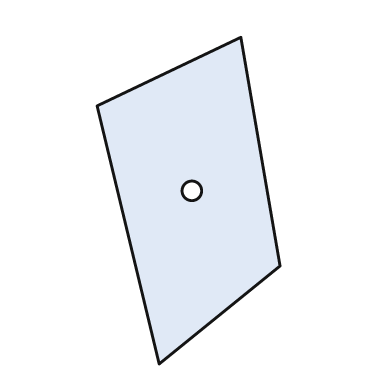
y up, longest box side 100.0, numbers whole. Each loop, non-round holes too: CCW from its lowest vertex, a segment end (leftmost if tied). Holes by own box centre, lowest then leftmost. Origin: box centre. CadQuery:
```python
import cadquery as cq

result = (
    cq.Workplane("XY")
    .moveTo(-9.0, -50.0)
    .lineTo(28.0, -20.0)
    .lineTo(16.0, 50.0)
    .lineTo(-28.0, 29.0)
    .close()
    .moveTo(1.0, 3.0)
    .circle(3.0)
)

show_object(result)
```